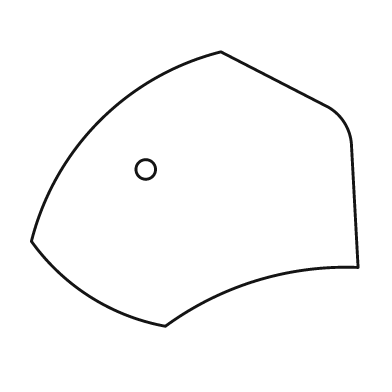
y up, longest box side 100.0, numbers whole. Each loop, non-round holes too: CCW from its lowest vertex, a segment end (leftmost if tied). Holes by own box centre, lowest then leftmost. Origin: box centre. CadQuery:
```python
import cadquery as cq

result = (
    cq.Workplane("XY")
    .moveTo(-9.0, -42.0)
    .threePointArc((19.0, -28.0), (50.0, -24.0))
    .lineTo(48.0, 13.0)
    .threePointArc((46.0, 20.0), (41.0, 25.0))
    .lineTo(8.0, 42.0)
    .threePointArc((-29.0, 21.0), (-50.0, -16.0))
    .threePointArc((-32.0, -33.0), (-9.0, -42.0))
    .close()
    .moveTo(-15.0, 6.0)
    .circle(3.0)
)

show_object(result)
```